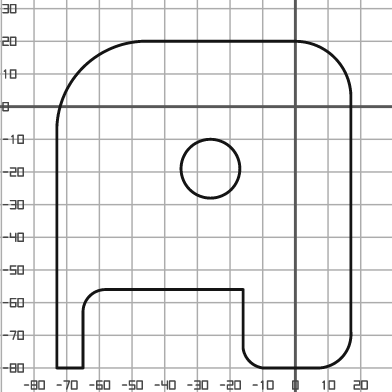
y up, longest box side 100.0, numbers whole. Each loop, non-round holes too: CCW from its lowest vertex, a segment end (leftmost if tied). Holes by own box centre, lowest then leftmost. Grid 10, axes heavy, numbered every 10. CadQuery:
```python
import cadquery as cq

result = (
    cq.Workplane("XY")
    .moveTo(-73.0, -80.0)
    .lineTo(-65.0, -80.0)
    .lineTo(-65.0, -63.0)
    .threePointArc((-63.0, -58.0), (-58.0, -56.0))
    .lineTo(-16.0, -56.0)
    .lineTo(-16.0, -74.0)
    .threePointArc((-14.0, -78.0), (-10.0, -80.0))
    .lineTo(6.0, -80.0)
    .threePointArc((14.0, -77.0), (17.0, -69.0))
    .lineTo(17.0, 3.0)
    .threePointArc((12.0, 15.0), (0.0, 20.0))
    .lineTo(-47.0, 20.0)
    .threePointArc((-65.0, 12.0), (-73.0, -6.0))
    .close()
    .moveTo(-26.0, -19.0)
    .circle(9.0)
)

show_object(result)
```